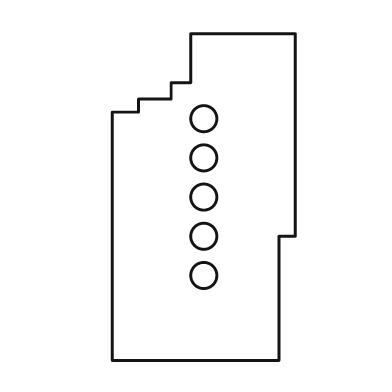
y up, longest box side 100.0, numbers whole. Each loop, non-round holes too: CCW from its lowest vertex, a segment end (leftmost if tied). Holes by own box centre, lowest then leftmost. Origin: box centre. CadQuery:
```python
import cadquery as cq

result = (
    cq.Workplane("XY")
    .moveTo(-28.0, -50.0)
    .lineTo(23.0, -50.0)
    .lineTo(23.0, -12.0)
    .lineTo(28.0, -12.0)
    .lineTo(28.0, 50.0)
    .lineTo(-4.0, 50.0)
    .lineTo(-4.0, 35.0)
    .lineTo(-10.0, 35.0)
    .lineTo(-10.0, 30.0)
    .lineTo(-20.0, 30.0)
    .lineTo(-20.0, 26.0)
    .lineTo(-28.0, 26.0)
    .close()
    .moveTo(0.0, -24.0)
    .circle(4.0)
    .moveTo(0.0, -12.0)
    .circle(4.0)
    .moveTo(0.0, 0.0)
    .circle(4.0)
    .moveTo(0.0, 12.0)
    .circle(4.0)
    .moveTo(0.0, 24.0)
    .circle(4.0)
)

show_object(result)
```